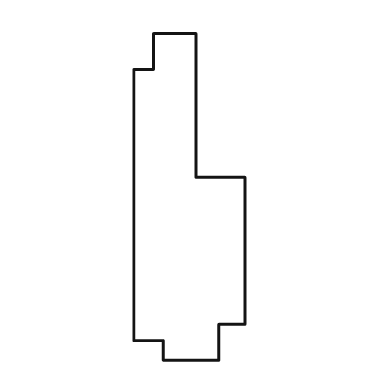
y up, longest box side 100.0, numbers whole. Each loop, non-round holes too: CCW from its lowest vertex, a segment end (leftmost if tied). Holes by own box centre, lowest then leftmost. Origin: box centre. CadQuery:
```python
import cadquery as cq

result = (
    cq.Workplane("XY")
    .moveTo(-8.0, -50.0)
    .lineTo(9.0, -50.0)
    .lineTo(9.0, -39.0)
    .lineTo(17.0, -39.0)
    .lineTo(17.0, 6.0)
    .lineTo(2.0, 6.0)
    .lineTo(2.0, 50.0)
    .lineTo(-11.0, 50.0)
    .lineTo(-11.0, 39.0)
    .lineTo(-17.0, 39.0)
    .lineTo(-17.0, -44.0)
    .lineTo(-8.0, -44.0)
    .close()
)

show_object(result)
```